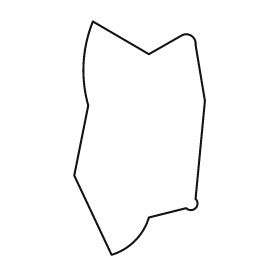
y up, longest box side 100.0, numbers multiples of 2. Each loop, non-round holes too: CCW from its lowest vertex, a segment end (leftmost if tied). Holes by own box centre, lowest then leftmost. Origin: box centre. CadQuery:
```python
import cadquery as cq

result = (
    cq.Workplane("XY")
    .moveTo(-12.0, -50.0)
    .threePointArc((-2.0, -44.0), (4.0, -34.0))
    .lineTo(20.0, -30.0)
    .threePointArc((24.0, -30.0), (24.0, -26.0))
    .lineTo(28.0, 16.0)
    .lineTo(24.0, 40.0)
    .threePointArc((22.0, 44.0), (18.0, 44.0))
    .lineTo(4.0, 36.0)
    .lineTo(-20.0, 50.0)
    .threePointArc((-24.0, 32.0), (-22.0, 14.0))
    .lineTo(-28.0, -16.0)
    .close()
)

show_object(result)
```